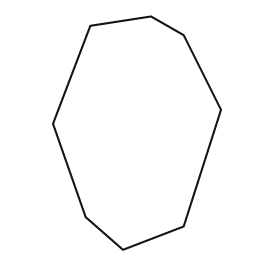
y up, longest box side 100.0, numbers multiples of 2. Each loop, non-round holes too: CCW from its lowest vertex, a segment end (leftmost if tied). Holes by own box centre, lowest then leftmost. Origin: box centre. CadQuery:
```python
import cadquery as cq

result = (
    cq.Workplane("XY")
    .moveTo(-6.0, -50.0)
    .lineTo(20.0, -40.0)
    .lineTo(36.0, 10.0)
    .lineTo(20.0, 42.0)
    .lineTo(6.0, 50.0)
    .lineTo(-20.0, 46.0)
    .lineTo(-36.0, 4.0)
    .lineTo(-22.0, -36.0)
    .close()
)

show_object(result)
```